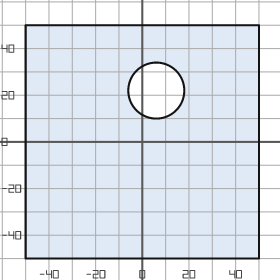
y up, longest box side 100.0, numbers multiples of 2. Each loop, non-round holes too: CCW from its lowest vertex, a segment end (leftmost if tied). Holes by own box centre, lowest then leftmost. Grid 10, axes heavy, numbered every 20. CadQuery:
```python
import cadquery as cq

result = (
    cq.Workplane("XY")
    .moveTo(-50.0, -50.0)
    .lineTo(50.0, -50.0)
    .lineTo(50.0, 50.0)
    .lineTo(-50.0, 50.0)
    .close()
    .moveTo(6.0, 22.0)
    .circle(12.0)
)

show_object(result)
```